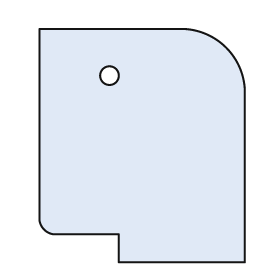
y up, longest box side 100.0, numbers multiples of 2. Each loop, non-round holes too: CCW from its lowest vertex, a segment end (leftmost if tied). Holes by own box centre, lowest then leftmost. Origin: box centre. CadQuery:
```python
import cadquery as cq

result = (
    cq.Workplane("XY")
    .moveTo(-10.0, -50.0)
    .lineTo(44.0, -50.0)
    .lineTo(44.0, 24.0)
    .threePointArc((36.0, 42.0), (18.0, 50.0))
    .lineTo(-44.0, 50.0)
    .lineTo(-44.0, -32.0)
    .threePointArc((-42.0, -36.0), (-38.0, -38.0))
    .lineTo(-10.0, -38.0)
    .close()
    .moveTo(-14.0, 30.0)
    .circle(4.0)
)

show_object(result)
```